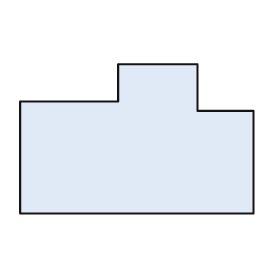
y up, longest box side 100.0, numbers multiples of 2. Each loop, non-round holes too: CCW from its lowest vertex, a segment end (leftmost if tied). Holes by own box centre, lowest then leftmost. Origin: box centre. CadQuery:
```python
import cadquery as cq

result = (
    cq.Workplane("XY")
    .moveTo(-50.0, -32.0)
    .lineTo(50.0, -32.0)
    .lineTo(50.0, 12.0)
    .lineTo(26.0, 12.0)
    .lineTo(26.0, 32.0)
    .lineTo(-8.0, 32.0)
    .lineTo(-8.0, 16.0)
    .lineTo(-50.0, 16.0)
    .close()
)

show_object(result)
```